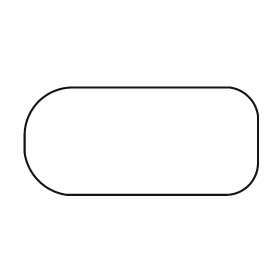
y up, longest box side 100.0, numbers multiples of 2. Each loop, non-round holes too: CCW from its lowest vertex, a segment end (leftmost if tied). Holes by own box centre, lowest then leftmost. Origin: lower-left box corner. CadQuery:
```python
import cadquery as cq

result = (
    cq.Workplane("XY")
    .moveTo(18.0, 0.0)
    .lineTo(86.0, 0.0)
    .threePointArc((96.0, 4.0), (100.0, 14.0))
    .lineTo(100.0, 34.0)
    .threePointArc((96.0, 42.0), (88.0, 46.0))
    .lineTo(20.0, 46.0)
    .threePointArc((6.0, 40.0), (0.0, 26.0))
    .lineTo(0.0, 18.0)
    .threePointArc((6.0, 6.0), (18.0, 0.0))
    .close()
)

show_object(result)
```